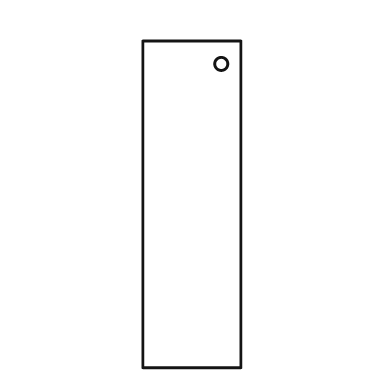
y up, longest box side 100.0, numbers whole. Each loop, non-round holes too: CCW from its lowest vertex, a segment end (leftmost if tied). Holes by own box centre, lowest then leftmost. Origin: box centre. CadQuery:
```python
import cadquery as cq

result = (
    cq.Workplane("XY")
    .moveTo(-15.0, -50.0)
    .lineTo(15.0, -50.0)
    .lineTo(15.0, 50.0)
    .lineTo(-15.0, 50.0)
    .close()
    .moveTo(9.0, 43.0)
    .circle(2.0)
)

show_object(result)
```